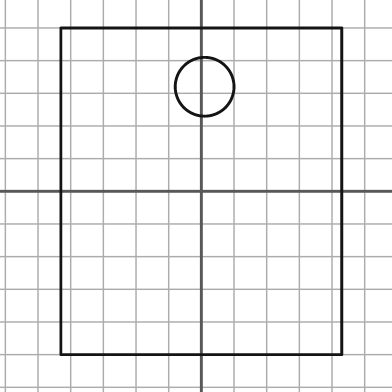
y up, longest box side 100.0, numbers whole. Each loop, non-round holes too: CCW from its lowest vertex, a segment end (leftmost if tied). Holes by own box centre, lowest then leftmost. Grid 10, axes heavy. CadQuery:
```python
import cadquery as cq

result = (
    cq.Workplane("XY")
    .moveTo(-43.0, -50.0)
    .lineTo(43.0, -50.0)
    .lineTo(43.0, 50.0)
    .lineTo(-43.0, 50.0)
    .close()
    .moveTo(1.0, 32.0)
    .circle(9.0)
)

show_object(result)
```